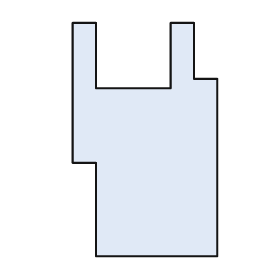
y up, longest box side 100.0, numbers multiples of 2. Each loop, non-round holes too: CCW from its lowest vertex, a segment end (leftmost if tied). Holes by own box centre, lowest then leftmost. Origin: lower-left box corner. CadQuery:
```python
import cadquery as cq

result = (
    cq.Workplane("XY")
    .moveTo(10.0, 0.0)
    .lineTo(62.0, 0.0)
    .lineTo(62.0, 76.0)
    .lineTo(52.0, 76.0)
    .lineTo(52.0, 100.0)
    .lineTo(42.0, 100.0)
    .lineTo(42.0, 72.0)
    .lineTo(10.0, 72.0)
    .lineTo(10.0, 100.0)
    .lineTo(0.0, 100.0)
    .lineTo(0.0, 40.0)
    .lineTo(10.0, 40.0)
    .close()
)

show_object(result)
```